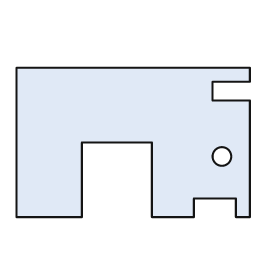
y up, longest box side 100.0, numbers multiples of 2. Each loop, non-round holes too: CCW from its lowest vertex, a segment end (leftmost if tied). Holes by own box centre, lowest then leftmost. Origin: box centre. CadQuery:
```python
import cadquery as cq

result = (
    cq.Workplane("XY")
    .moveTo(-50.0, -32.0)
    .lineTo(-22.0, -32.0)
    .lineTo(-22.0, 0.0)
    .lineTo(8.0, 0.0)
    .lineTo(8.0, -32.0)
    .lineTo(26.0, -32.0)
    .lineTo(26.0, -24.0)
    .lineTo(44.0, -24.0)
    .lineTo(44.0, -32.0)
    .lineTo(50.0, -32.0)
    .lineTo(50.0, 18.0)
    .lineTo(34.0, 18.0)
    .lineTo(34.0, 26.0)
    .lineTo(50.0, 26.0)
    .lineTo(50.0, 32.0)
    .lineTo(-50.0, 32.0)
    .close()
    .moveTo(38.0, -6.0)
    .circle(4.0)
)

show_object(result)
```